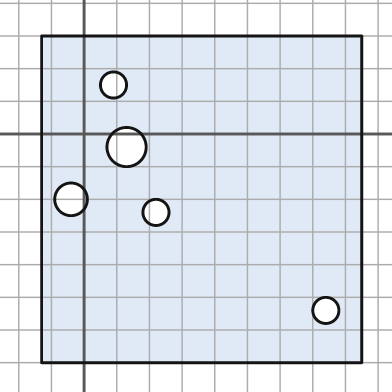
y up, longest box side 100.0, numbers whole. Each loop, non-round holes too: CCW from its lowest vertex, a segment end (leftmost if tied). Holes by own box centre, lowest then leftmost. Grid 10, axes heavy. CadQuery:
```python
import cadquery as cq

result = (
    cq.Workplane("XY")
    .moveTo(-13.0, -70.0)
    .lineTo(85.0, -70.0)
    .lineTo(85.0, 30.0)
    .lineTo(-13.0, 30.0)
    .close()
    .moveTo(74.0, -54.0)
    .circle(4.0)
    .moveTo(22.0, -24.0)
    .circle(4.0)
    .moveTo(-4.0, -20.0)
    .circle(5.0)
    .moveTo(13.0, -4.0)
    .circle(6.0)
    .moveTo(9.0, 15.0)
    .circle(4.0)
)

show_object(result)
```